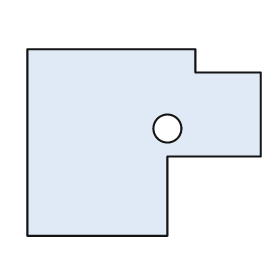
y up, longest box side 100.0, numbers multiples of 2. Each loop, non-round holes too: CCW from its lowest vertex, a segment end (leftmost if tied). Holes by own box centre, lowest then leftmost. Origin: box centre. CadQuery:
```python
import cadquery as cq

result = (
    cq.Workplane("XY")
    .moveTo(-50.0, -40.0)
    .lineTo(10.0, -40.0)
    .lineTo(10.0, -6.0)
    .lineTo(50.0, -6.0)
    .lineTo(50.0, 30.0)
    .lineTo(22.0, 30.0)
    .lineTo(22.0, 40.0)
    .lineTo(-50.0, 40.0)
    .close()
    .moveTo(10.0, 6.0)
    .circle(6.0)
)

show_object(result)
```